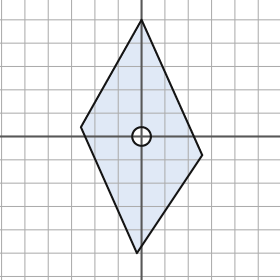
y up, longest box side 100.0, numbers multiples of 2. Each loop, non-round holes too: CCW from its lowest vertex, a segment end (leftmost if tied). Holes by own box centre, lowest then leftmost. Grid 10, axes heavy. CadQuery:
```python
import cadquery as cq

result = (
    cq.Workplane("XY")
    .moveTo(-2.0, -50.0)
    .lineTo(26.0, -8.0)
    .lineTo(0.0, 50.0)
    .lineTo(-26.0, 4.0)
    .close()
    .moveTo(0.0, 0.0)
    .circle(4.0)
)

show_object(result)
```